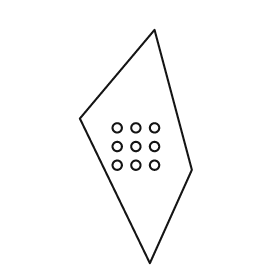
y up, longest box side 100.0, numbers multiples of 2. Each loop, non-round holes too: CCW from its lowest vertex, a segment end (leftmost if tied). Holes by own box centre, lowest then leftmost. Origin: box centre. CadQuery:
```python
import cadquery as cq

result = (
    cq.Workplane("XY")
    .moveTo(6.0, -50.0)
    .lineTo(24.0, -10.0)
    .lineTo(8.0, 50.0)
    .lineTo(-24.0, 12.0)
    .close()
    .moveTo(-8.0, -8.0)
    .circle(2.0)
    .moveTo(0.0, -8.0)
    .circle(2.0)
    .moveTo(8.0, -8.0)
    .circle(2.0)
    .moveTo(-8.0, 0.0)
    .circle(2.0)
    .moveTo(0.0, 0.0)
    .circle(2.0)
    .moveTo(8.0, 0.0)
    .circle(2.0)
    .moveTo(-8.0, 8.0)
    .circle(2.0)
    .moveTo(0.0, 8.0)
    .circle(2.0)
    .moveTo(8.0, 8.0)
    .circle(2.0)
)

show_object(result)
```